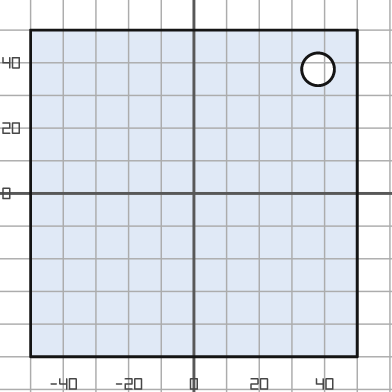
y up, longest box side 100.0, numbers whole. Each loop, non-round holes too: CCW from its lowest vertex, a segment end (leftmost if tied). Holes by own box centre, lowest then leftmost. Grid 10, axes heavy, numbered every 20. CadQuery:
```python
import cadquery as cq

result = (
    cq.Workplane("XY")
    .moveTo(-50.0, -50.0)
    .lineTo(50.0, -50.0)
    .lineTo(50.0, 50.0)
    .lineTo(-50.0, 50.0)
    .close()
    .moveTo(38.0, 38.0)
    .circle(5.0)
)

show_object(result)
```